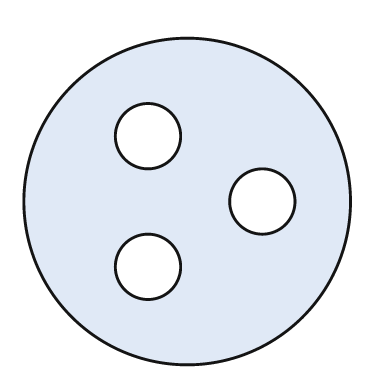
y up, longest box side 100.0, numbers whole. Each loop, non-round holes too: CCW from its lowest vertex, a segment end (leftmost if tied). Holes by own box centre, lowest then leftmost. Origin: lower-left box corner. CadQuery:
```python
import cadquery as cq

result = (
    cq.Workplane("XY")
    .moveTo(50.0, 50.0)
    .circle(50.0)
    .moveTo(38.0, 30.0)
    .circle(10.0)
    .moveTo(73.0, 50.0)
    .circle(10.0)
    .moveTo(38.0, 70.0)
    .circle(10.0)
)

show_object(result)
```